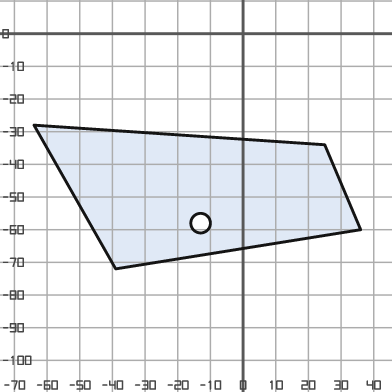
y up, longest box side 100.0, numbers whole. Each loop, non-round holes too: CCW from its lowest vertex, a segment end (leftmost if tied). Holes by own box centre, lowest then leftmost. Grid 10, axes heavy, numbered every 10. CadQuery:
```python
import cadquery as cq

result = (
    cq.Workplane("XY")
    .moveTo(-39.0, -72.0)
    .lineTo(36.0, -60.0)
    .lineTo(25.0, -34.0)
    .lineTo(-64.0, -28.0)
    .close()
    .moveTo(-13.0, -58.0)
    .circle(3.0)
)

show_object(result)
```